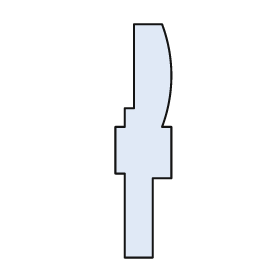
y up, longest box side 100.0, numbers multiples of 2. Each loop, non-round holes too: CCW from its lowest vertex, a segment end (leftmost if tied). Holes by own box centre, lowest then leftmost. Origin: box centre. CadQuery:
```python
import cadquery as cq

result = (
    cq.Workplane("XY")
    .moveTo(-8.0, -50.0)
    .lineTo(4.0, -50.0)
    .lineTo(4.0, -16.0)
    .lineTo(12.0, -16.0)
    .lineTo(12.0, 6.0)
    .lineTo(8.0, 6.0)
    .threePointArc((12.0, 28.0), (8.0, 50.0))
    .lineTo(-4.0, 50.0)
    .lineTo(-4.0, 14.0)
    .lineTo(-8.0, 14.0)
    .lineTo(-8.0, 6.0)
    .lineTo(-12.0, 6.0)
    .lineTo(-12.0, -14.0)
    .lineTo(-8.0, -14.0)
    .close()
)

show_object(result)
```